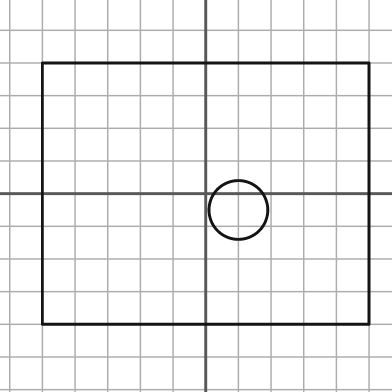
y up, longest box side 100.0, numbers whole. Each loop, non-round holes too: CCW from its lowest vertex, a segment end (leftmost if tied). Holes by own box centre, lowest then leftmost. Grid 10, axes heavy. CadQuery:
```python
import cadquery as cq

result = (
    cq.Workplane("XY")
    .moveTo(-50.0, -40.0)
    .lineTo(50.0, -40.0)
    .lineTo(50.0, 40.0)
    .lineTo(-50.0, 40.0)
    .close()
    .moveTo(10.0, -5.0)
    .circle(9.0)
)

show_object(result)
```